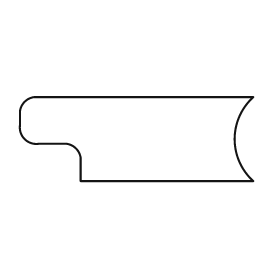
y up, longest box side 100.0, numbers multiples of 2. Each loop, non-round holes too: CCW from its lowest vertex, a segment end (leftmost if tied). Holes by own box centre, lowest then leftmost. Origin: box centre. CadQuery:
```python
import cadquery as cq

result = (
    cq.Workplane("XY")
    .moveTo(-24.0, -18.0)
    .lineTo(50.0, -18.0)
    .threePointArc((42.0, 0.0), (50.0, 18.0))
    .lineTo(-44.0, 18.0)
    .threePointArc((-48.0, 16.0), (-50.0, 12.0))
    .lineTo(-50.0, 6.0)
    .threePointArc((-48.0, 0.0), (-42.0, -2.0))
    .lineTo(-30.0, -2.0)
    .threePointArc((-26.0, -4.0), (-24.0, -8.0))
    .close()
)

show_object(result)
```